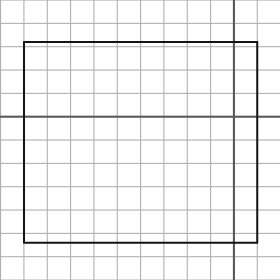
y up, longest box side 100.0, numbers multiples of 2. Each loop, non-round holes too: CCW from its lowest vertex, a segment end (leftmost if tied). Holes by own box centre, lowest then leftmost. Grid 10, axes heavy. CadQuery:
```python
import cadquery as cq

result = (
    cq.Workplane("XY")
    .moveTo(-90.0, -54.0)
    .lineTo(10.0, -54.0)
    .lineTo(10.0, 32.0)
    .lineTo(-90.0, 32.0)
    .close()
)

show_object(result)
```